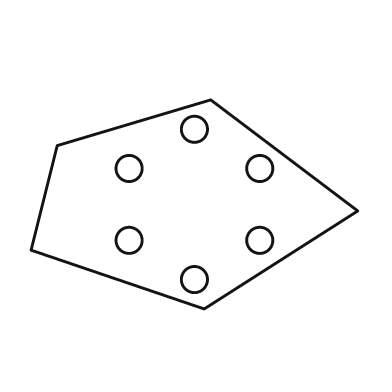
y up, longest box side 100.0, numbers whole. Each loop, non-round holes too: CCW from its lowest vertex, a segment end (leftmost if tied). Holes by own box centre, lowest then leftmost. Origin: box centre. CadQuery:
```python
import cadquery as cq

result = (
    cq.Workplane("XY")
    .moveTo(3.0, -32.0)
    .lineTo(50.0, -2.0)
    .lineTo(5.0, 32.0)
    .lineTo(-42.0, 18.0)
    .lineTo(-50.0, -14.0)
    .close()
    .moveTo(0.0, -23.0)
    .circle(4.0)
    .moveTo(-20.0, -11.0)
    .circle(4.0)
    .moveTo(20.0, -11.0)
    .circle(4.0)
    .moveTo(-20.0, 11.0)
    .circle(4.0)
    .moveTo(20.0, 11.0)
    .circle(4.0)
    .moveTo(0.0, 23.0)
    .circle(4.0)
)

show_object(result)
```